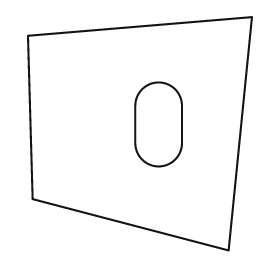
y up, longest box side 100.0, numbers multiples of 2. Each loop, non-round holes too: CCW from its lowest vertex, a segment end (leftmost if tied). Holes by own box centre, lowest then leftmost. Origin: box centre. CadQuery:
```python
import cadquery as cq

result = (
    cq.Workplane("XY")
    .moveTo(38.0, -50.0)
    .lineTo(48.0, 50.0)
    .lineTo(-48.0, 42.0)
    .lineTo(-46.0, -28.0)
    .close()
    .moveTo(-2.0, -4.0)
    .threePointArc((8.0, -14.0), (18.0, -4.0))
    .lineTo(18.0, 12.0)
    .threePointArc((8.0, 22.0), (-2.0, 12.0))
    .close()
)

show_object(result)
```